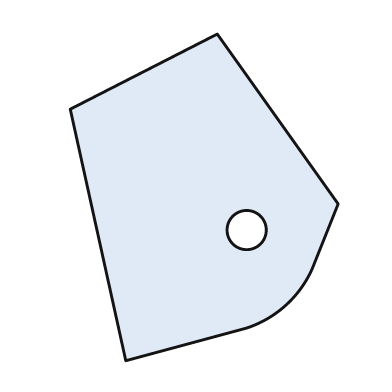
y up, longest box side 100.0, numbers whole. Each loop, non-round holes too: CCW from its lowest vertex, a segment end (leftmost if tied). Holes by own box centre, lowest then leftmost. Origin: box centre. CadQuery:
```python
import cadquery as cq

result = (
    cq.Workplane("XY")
    .moveTo(-24.0, -50.0)
    .lineTo(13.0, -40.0)
    .threePointArc((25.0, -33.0), (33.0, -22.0))
    .lineTo(41.0, -2.0)
    .lineTo(4.0, 50.0)
    .lineTo(-41.0, 27.0)
    .close()
    .moveTo(13.0, -10.0)
    .circle(6.0)
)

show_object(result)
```